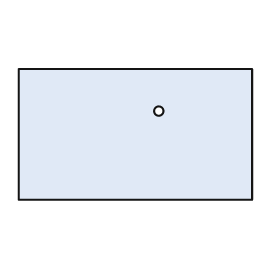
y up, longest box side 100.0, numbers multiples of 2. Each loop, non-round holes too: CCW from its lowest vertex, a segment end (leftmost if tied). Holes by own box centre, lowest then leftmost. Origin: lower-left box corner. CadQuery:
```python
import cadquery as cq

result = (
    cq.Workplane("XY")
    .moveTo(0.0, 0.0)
    .lineTo(100.0, 0.0)
    .lineTo(100.0, 56.0)
    .lineTo(0.0, 56.0)
    .close()
    .moveTo(60.0, 38.0)
    .circle(2.0)
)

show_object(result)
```